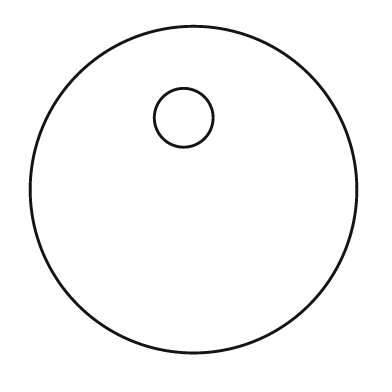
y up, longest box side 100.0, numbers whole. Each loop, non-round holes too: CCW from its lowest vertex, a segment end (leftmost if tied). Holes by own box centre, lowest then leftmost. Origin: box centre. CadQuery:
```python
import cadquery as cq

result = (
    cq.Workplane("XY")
    .moveTo(0.0, 0.0)
    .circle(50.0)
    .moveTo(-3.0, 22.0)
    .circle(9.0)
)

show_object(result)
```